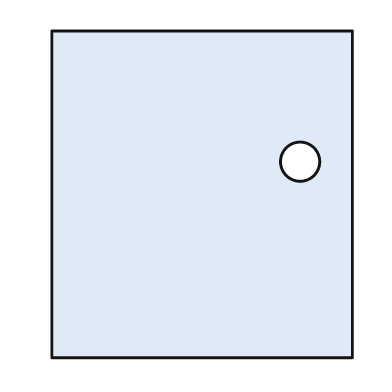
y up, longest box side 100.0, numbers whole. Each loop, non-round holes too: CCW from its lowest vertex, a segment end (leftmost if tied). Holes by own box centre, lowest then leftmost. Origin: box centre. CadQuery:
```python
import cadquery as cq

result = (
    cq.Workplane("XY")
    .moveTo(-46.0, -50.0)
    .lineTo(46.0, -50.0)
    .lineTo(46.0, 50.0)
    .lineTo(-46.0, 50.0)
    .close()
    .moveTo(30.0, 10.0)
    .circle(6.0)
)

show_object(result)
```